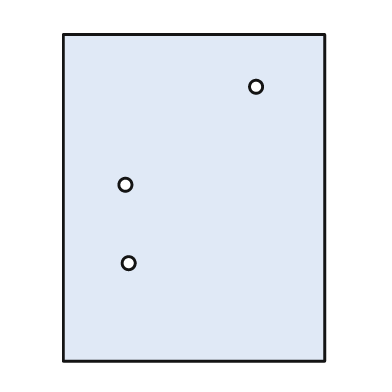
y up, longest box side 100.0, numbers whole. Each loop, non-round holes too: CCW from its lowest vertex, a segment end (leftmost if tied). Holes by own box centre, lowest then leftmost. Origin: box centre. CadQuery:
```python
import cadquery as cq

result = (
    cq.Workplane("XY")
    .moveTo(-40.0, -50.0)
    .lineTo(40.0, -50.0)
    .lineTo(40.0, 50.0)
    .lineTo(-40.0, 50.0)
    .close()
    .moveTo(-20.0, -20.0)
    .circle(2.0)
    .moveTo(-21.0, 4.0)
    .circle(2.0)
    .moveTo(19.0, 34.0)
    .circle(2.0)
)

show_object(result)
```